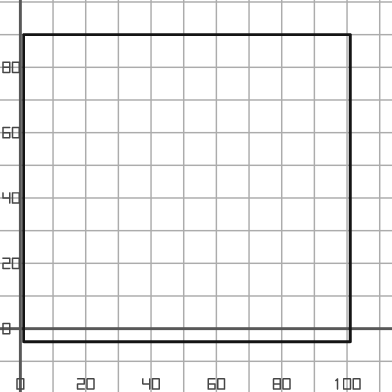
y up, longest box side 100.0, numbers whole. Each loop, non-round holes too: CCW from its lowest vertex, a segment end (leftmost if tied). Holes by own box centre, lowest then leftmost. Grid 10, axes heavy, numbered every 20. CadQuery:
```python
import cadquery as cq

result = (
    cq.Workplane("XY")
    .moveTo(1.0, -4.0)
    .lineTo(101.0, -4.0)
    .lineTo(101.0, 90.0)
    .lineTo(1.0, 90.0)
    .close()
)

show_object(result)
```